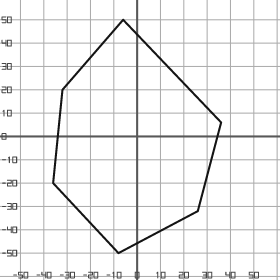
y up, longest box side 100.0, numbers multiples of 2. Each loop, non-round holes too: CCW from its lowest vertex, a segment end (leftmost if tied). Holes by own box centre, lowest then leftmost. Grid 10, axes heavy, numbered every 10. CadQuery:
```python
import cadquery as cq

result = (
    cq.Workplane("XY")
    .moveTo(-8.0, -50.0)
    .lineTo(26.0, -32.0)
    .lineTo(36.0, 6.0)
    .lineTo(-6.0, 50.0)
    .lineTo(-32.0, 20.0)
    .lineTo(-36.0, -20.0)
    .close()
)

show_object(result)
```